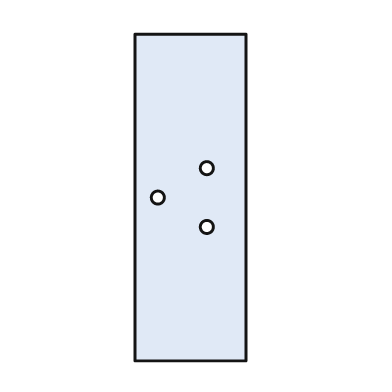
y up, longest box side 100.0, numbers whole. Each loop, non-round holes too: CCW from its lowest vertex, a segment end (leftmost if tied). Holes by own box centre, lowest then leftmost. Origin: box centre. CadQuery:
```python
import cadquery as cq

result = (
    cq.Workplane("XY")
    .moveTo(-17.0, -50.0)
    .lineTo(17.0, -50.0)
    .lineTo(17.0, 50.0)
    .lineTo(-17.0, 50.0)
    .close()
    .moveTo(5.0, -9.0)
    .circle(2.0)
    .moveTo(-10.0, 0.0)
    .circle(2.0)
    .moveTo(5.0, 9.0)
    .circle(2.0)
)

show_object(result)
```